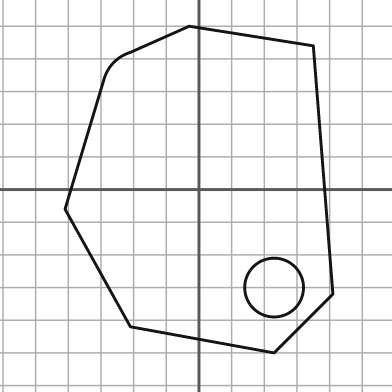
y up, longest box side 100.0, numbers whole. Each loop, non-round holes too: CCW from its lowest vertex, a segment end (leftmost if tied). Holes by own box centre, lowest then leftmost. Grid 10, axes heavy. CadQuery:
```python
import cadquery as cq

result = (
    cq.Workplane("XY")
    .moveTo(23.0, -50.0)
    .lineTo(41.0, -32.0)
    .lineTo(35.0, 44.0)
    .lineTo(-3.0, 50.0)
    .lineTo(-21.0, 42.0)
    .threePointArc((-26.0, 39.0), (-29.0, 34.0))
    .lineTo(-41.0, -6.0)
    .lineTo(-21.0, -42.0)
    .close()
    .moveTo(23.0, -30.0)
    .circle(9.0)
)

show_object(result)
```